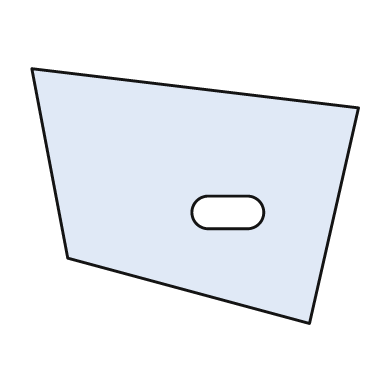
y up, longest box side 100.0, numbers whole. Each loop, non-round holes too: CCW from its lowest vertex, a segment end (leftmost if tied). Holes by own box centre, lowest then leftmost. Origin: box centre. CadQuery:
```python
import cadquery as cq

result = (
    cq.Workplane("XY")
    .moveTo(35.0, -39.0)
    .lineTo(50.0, 27.0)
    .lineTo(-50.0, 39.0)
    .lineTo(-39.0, -19.0)
    .close()
    .moveTo(4.0, -10.0)
    .lineTo(16.0, -10.0)
    .threePointArc((21.0, -5.0), (16.0, 0.0))
    .lineTo(4.0, 0.0)
    .threePointArc((-1.0, -5.0), (4.0, -10.0))
    .close()
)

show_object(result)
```